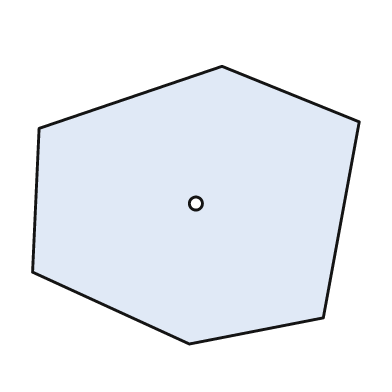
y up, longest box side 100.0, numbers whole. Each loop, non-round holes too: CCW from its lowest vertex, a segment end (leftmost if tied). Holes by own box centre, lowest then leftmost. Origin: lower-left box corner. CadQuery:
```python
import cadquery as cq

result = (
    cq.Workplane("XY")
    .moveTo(48.0, 0.0)
    .lineTo(89.0, 8.0)
    .lineTo(100.0, 68.0)
    .lineTo(58.0, 85.0)
    .lineTo(2.0, 66.0)
    .lineTo(0.0, 22.0)
    .close()
    .moveTo(50.0, 43.0)
    .circle(2.0)
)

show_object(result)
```